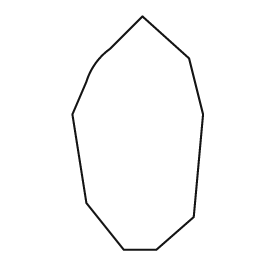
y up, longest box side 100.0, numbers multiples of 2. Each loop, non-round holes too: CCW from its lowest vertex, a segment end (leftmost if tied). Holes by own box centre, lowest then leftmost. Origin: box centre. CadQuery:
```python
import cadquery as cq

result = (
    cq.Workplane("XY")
    .moveTo(-6.0, -50.0)
    .lineTo(8.0, -50.0)
    .lineTo(24.0, -36.0)
    .lineTo(28.0, 8.0)
    .lineTo(22.0, 32.0)
    .lineTo(2.0, 50.0)
    .lineTo(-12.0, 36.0)
    .threePointArc((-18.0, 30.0), (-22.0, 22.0))
    .lineTo(-28.0, 8.0)
    .lineTo(-22.0, -30.0)
    .close()
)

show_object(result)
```